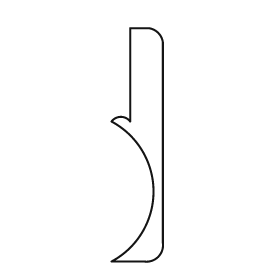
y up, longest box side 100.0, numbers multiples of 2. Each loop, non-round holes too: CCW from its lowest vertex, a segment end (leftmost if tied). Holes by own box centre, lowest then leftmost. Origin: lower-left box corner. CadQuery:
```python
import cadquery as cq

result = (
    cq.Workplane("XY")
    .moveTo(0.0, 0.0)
    .lineTo(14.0, 0.0)
    .threePointArc((20.0, 2.0), (22.0, 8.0))
    .lineTo(22.0, 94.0)
    .threePointArc((20.0, 98.0), (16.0, 100.0))
    .lineTo(8.0, 100.0)
    .lineTo(8.0, 60.0)
    .threePointArc((4.0, 62.0), (0.0, 60.0))
    .threePointArc((18.0, 30.0), (0.0, 0.0))
    .close()
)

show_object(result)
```